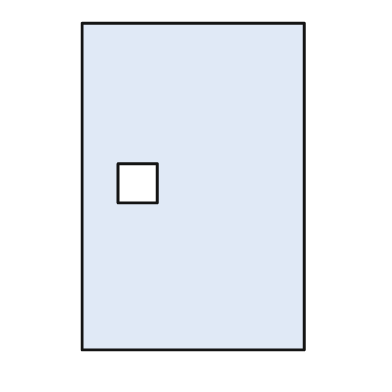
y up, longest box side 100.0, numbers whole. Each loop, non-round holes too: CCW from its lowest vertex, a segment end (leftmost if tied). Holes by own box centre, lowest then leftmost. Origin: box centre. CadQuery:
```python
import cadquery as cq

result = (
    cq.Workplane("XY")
    .moveTo(-34.0, -50.0)
    .lineTo(34.0, -50.0)
    .lineTo(34.0, 50.0)
    .lineTo(-34.0, 50.0)
    .close()
    .moveTo(-23.0, -5.0)
    .lineTo(-11.0, -5.0)
    .lineTo(-11.0, 7.0)
    .lineTo(-23.0, 7.0)
    .close()
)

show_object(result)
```